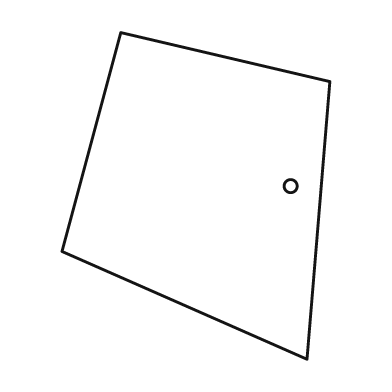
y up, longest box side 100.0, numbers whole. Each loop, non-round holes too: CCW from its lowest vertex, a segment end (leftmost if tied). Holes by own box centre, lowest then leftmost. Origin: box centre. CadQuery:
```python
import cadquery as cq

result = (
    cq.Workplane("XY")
    .moveTo(34.0, -50.0)
    .lineTo(41.0, 35.0)
    .lineTo(-23.0, 50.0)
    .lineTo(-41.0, -17.0)
    .close()
    .moveTo(29.0, 3.0)
    .circle(2.0)
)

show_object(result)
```